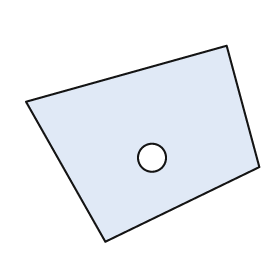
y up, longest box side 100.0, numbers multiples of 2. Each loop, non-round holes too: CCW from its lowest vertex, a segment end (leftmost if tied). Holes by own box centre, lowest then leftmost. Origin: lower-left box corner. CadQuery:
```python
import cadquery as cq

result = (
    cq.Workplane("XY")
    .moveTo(34.0, 0.0)
    .lineTo(100.0, 32.0)
    .lineTo(86.0, 84.0)
    .lineTo(0.0, 60.0)
    .close()
    .moveTo(54.0, 36.0)
    .circle(6.0)
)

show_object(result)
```